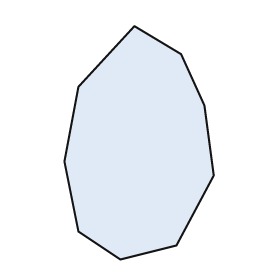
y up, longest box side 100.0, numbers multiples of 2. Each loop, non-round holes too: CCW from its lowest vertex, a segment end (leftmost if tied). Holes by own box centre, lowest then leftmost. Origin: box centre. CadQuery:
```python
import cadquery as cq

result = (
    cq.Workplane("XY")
    .moveTo(-8.0, -50.0)
    .lineTo(16.0, -44.0)
    .lineTo(32.0, -14.0)
    .lineTo(28.0, 16.0)
    .lineTo(18.0, 38.0)
    .lineTo(-2.0, 50.0)
    .lineTo(-26.0, 24.0)
    .lineTo(-32.0, -8.0)
    .lineTo(-26.0, -38.0)
    .close()
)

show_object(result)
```